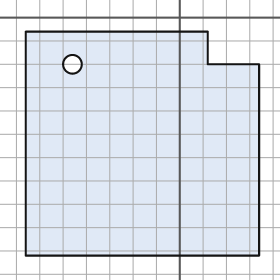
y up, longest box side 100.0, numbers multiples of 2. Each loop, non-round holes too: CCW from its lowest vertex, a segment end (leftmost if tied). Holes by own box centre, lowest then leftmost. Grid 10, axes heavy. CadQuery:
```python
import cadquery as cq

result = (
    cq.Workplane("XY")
    .moveTo(-66.0, -102.0)
    .lineTo(34.0, -102.0)
    .lineTo(34.0, -20.0)
    .lineTo(12.0, -20.0)
    .lineTo(12.0, -6.0)
    .lineTo(-66.0, -6.0)
    .close()
    .moveTo(-46.0, -20.0)
    .circle(4.0)
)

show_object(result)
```